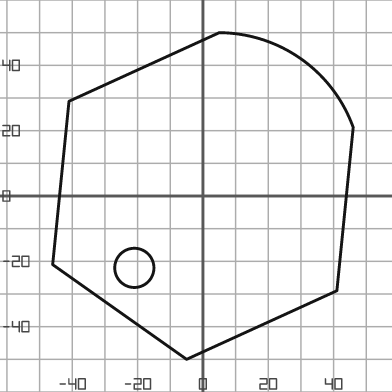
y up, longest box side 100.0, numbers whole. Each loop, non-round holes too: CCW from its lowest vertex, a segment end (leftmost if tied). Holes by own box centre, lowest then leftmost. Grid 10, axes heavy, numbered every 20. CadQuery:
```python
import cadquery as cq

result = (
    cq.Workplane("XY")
    .moveTo(-5.0, -50.0)
    .lineTo(41.0, -29.0)
    .lineTo(46.0, 21.0)
    .threePointArc((30.0, 42.0), (5.0, 50.0))
    .lineTo(-41.0, 29.0)
    .lineTo(-46.0, -21.0)
    .close()
    .moveTo(-21.0, -22.0)
    .circle(6.0)
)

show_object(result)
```